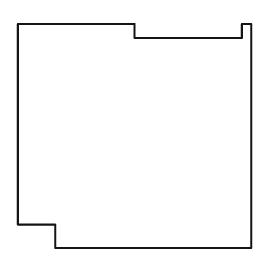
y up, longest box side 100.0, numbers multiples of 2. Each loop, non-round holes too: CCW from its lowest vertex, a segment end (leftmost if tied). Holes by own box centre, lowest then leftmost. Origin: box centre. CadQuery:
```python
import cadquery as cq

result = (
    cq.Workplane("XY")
    .moveTo(-34.0, -48.0)
    .lineTo(50.0, -48.0)
    .lineTo(50.0, 48.0)
    .lineTo(46.0, 48.0)
    .lineTo(46.0, 42.0)
    .lineTo(0.0, 42.0)
    .lineTo(0.0, 48.0)
    .lineTo(-50.0, 48.0)
    .lineTo(-50.0, -38.0)
    .lineTo(-34.0, -38.0)
    .close()
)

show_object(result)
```